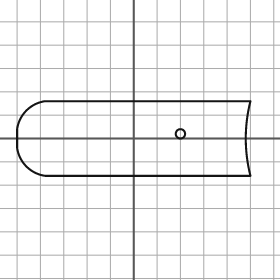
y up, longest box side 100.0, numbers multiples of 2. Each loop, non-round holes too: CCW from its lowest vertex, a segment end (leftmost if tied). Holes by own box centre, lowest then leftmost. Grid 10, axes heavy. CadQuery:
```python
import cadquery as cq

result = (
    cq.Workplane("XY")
    .moveTo(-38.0, -16.0)
    .lineTo(50.0, -16.0)
    .threePointArc((48.0, 0.0), (50.0, 16.0))
    .lineTo(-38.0, 16.0)
    .threePointArc((-46.0, 12.0), (-50.0, 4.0))
    .lineTo(-50.0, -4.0)
    .threePointArc((-46.0, -12.0), (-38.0, -16.0))
    .close()
    .moveTo(20.0, 2.0)
    .circle(2.0)
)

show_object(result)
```